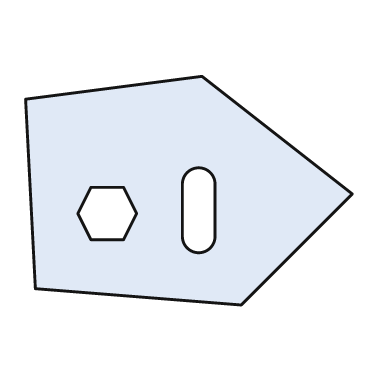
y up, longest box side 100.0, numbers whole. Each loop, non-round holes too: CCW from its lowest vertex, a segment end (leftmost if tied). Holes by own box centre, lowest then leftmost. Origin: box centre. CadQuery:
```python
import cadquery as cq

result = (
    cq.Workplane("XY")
    .moveTo(16.0, -35.0)
    .lineTo(50.0, -1.0)
    .lineTo(4.0, 35.0)
    .lineTo(-50.0, 28.0)
    .lineTo(-47.0, -30.0)
    .close()
    .moveTo(-30.0, -15.0)
    .lineTo(-20.0, -15.0)
    .lineTo(-16.0, -7.0)
    .lineTo(-20.0, 1.0)
    .lineTo(-30.0, 1.0)
    .lineTo(-34.0, -7.0)
    .close()
    .moveTo(-2.0, -14.0)
    .threePointArc((3.0, -19.0), (8.0, -14.0))
    .lineTo(8.0, 2.0)
    .threePointArc((3.0, 7.0), (-2.0, 2.0))
    .close()
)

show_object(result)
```